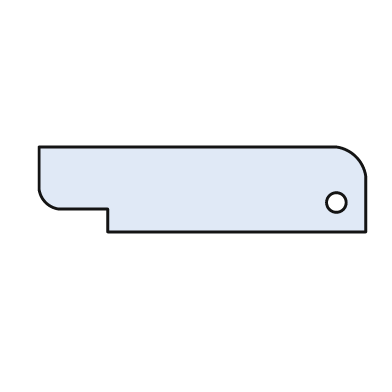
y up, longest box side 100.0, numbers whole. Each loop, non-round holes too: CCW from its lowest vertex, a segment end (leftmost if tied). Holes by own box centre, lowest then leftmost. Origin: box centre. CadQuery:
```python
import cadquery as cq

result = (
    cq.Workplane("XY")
    .moveTo(-29.0, -13.0)
    .lineTo(50.0, -13.0)
    .lineTo(50.0, 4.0)
    .threePointArc((47.0, 10.0), (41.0, 13.0))
    .lineTo(-50.0, 13.0)
    .lineTo(-50.0, 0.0)
    .threePointArc((-48.0, -4.0), (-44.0, -6.0))
    .lineTo(-29.0, -6.0)
    .close()
    .moveTo(41.0, -4.0)
    .circle(3.0)
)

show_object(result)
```